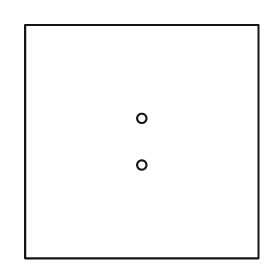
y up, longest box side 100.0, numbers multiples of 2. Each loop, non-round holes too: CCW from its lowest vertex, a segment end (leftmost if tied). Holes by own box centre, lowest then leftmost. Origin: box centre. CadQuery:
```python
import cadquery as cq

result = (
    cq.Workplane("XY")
    .moveTo(-50.0, -50.0)
    .lineTo(50.0, -50.0)
    .lineTo(50.0, 50.0)
    .lineTo(-50.0, 50.0)
    .close()
    .moveTo(0.0, -10.0)
    .circle(2.0)
    .moveTo(0.0, 10.0)
    .circle(2.0)
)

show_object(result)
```